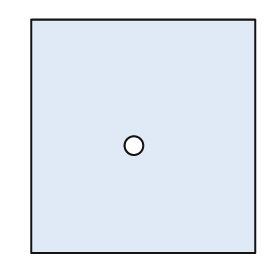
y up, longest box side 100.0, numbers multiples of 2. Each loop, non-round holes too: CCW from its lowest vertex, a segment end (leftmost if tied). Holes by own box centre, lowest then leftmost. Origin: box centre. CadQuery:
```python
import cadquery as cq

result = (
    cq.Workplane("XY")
    .moveTo(-48.0, -50.0)
    .lineTo(48.0, -50.0)
    .lineTo(48.0, 50.0)
    .lineTo(-48.0, 50.0)
    .close()
    .moveTo(-4.0, -4.0)
    .circle(4.0)
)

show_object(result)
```